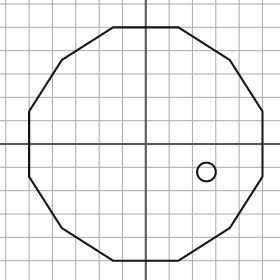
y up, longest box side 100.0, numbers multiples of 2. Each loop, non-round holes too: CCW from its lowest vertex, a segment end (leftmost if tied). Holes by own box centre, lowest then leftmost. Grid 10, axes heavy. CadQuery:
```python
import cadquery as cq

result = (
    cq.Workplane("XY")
    .moveTo(-14.0, -50.0)
    .lineTo(14.0, -50.0)
    .lineTo(36.0, -36.0)
    .lineTo(50.0, -14.0)
    .lineTo(50.0, 14.0)
    .lineTo(36.0, 36.0)
    .lineTo(14.0, 50.0)
    .lineTo(-14.0, 50.0)
    .lineTo(-36.0, 36.0)
    .lineTo(-50.0, 14.0)
    .lineTo(-50.0, -14.0)
    .lineTo(-36.0, -36.0)
    .close()
    .moveTo(26.0, -12.0)
    .circle(4.0)
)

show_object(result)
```